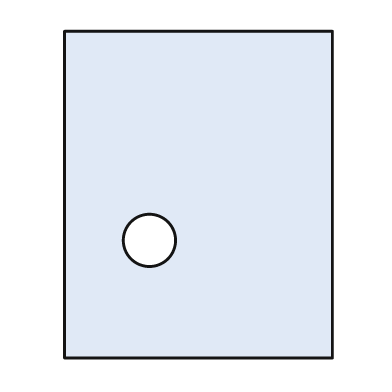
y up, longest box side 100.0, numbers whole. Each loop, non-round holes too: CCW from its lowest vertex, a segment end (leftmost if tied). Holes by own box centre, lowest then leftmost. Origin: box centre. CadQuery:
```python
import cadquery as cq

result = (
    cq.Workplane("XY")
    .moveTo(-41.0, -50.0)
    .lineTo(41.0, -50.0)
    .lineTo(41.0, 50.0)
    .lineTo(-41.0, 50.0)
    .close()
    .moveTo(-15.0, -14.0)
    .circle(8.0)
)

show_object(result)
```